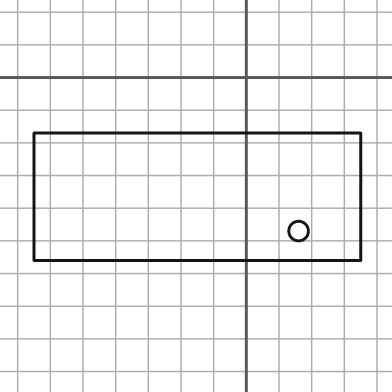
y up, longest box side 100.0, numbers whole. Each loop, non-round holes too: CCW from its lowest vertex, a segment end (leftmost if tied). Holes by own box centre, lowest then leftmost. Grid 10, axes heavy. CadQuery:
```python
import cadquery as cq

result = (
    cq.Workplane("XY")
    .moveTo(-65.0, -56.0)
    .lineTo(35.0, -56.0)
    .lineTo(35.0, -17.0)
    .lineTo(-65.0, -17.0)
    .close()
    .moveTo(16.0, -47.0)
    .circle(3.0)
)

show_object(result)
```